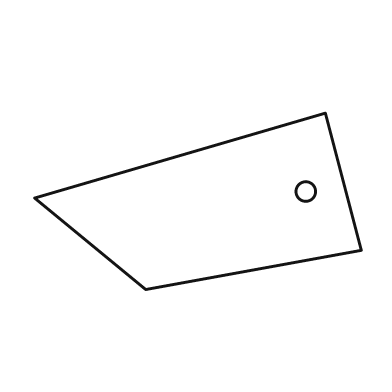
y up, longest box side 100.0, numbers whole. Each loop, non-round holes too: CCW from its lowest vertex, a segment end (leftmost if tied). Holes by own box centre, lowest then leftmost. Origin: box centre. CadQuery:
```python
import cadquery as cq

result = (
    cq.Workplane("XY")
    .moveTo(-16.0, -27.0)
    .lineTo(50.0, -15.0)
    .lineTo(39.0, 27.0)
    .lineTo(-50.0, 1.0)
    .close()
    .moveTo(33.0, 3.0)
    .circle(3.0)
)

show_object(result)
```